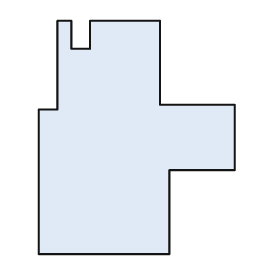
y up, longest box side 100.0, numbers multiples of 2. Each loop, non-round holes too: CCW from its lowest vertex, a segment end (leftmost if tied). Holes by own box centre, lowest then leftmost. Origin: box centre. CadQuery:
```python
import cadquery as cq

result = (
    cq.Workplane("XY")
    .moveTo(-42.0, -50.0)
    .lineTo(14.0, -50.0)
    .lineTo(14.0, -14.0)
    .lineTo(42.0, -14.0)
    .lineTo(42.0, 14.0)
    .lineTo(10.0, 14.0)
    .lineTo(10.0, 50.0)
    .lineTo(-20.0, 50.0)
    .lineTo(-20.0, 38.0)
    .lineTo(-28.0, 38.0)
    .lineTo(-28.0, 50.0)
    .lineTo(-34.0, 50.0)
    .lineTo(-34.0, 12.0)
    .lineTo(-42.0, 12.0)
    .close()
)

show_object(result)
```